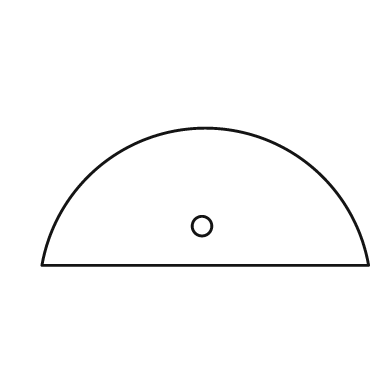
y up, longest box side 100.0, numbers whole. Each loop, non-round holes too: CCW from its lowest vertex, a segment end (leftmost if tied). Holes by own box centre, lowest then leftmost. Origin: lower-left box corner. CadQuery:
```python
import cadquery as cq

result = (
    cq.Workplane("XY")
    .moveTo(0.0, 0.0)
    .lineTo(100.0, 0.0)
    .threePointArc((50.0, 42.0), (0.0, 0.0))
    .close()
    .moveTo(49.0, 12.0)
    .circle(3.0)
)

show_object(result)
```